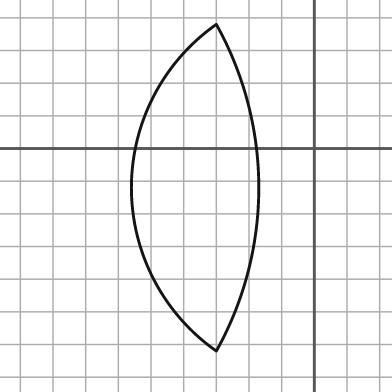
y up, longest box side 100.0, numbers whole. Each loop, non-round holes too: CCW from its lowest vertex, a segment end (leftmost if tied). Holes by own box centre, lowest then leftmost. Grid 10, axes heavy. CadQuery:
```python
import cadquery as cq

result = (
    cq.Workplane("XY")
    .moveTo(-30.0, -62.0)
    .threePointArc((-17.0, -12.0), (-30.0, 38.0))
    .threePointArc((-56.0, -12.0), (-30.0, -62.0))
    .close()
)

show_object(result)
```